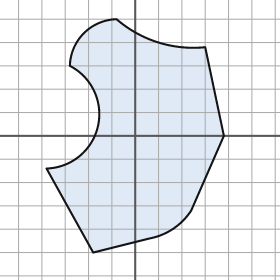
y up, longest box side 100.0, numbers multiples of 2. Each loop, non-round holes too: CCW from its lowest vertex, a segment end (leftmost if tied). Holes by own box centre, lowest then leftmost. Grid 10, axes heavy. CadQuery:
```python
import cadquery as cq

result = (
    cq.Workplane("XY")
    .moveTo(-18.0, -50.0)
    .lineTo(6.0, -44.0)
    .threePointArc((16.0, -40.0), (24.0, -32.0))
    .lineTo(38.0, 0.0)
    .lineTo(30.0, 38.0)
    .threePointArc((10.0, 40.0), (-8.0, 50.0))
    .threePointArc((-22.0, 44.0), (-28.0, 30.0))
    .threePointArc((-16.0, 4.0), (-38.0, -14.0))
    .close()
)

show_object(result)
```